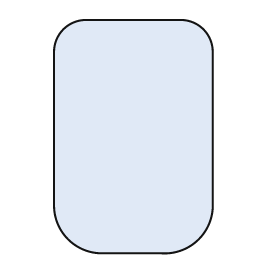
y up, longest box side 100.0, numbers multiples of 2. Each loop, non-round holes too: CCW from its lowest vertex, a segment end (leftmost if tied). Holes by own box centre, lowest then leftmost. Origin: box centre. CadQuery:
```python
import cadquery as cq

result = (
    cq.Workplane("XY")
    .moveTo(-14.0, -50.0)
    .lineTo(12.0, -50.0)
    .threePointArc((28.0, -44.0), (34.0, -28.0))
    .lineTo(34.0, 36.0)
    .threePointArc((30.0, 46.0), (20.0, 50.0))
    .lineTo(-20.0, 50.0)
    .threePointArc((-30.0, 46.0), (-34.0, 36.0))
    .lineTo(-34.0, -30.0)
    .threePointArc((-28.0, -44.0), (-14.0, -50.0))
    .close()
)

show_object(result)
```